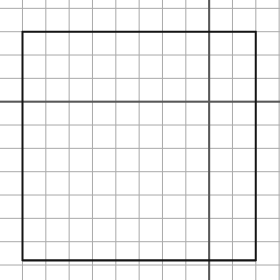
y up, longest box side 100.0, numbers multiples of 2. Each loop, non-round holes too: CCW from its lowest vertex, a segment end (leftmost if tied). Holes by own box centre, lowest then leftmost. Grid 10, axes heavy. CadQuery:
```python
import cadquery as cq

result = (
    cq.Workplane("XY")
    .moveTo(-80.0, -68.0)
    .lineTo(20.0, -68.0)
    .lineTo(20.0, 30.0)
    .lineTo(-80.0, 30.0)
    .close()
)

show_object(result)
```